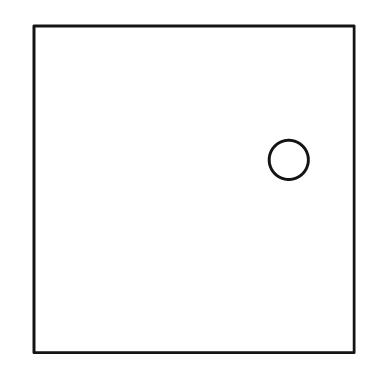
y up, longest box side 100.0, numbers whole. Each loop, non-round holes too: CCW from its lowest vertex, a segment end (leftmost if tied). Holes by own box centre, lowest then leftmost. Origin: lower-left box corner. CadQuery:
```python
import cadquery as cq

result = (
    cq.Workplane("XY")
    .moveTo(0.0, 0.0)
    .lineTo(98.0, 0.0)
    .lineTo(98.0, 100.0)
    .lineTo(0.0, 100.0)
    .close()
    .moveTo(78.0, 59.0)
    .circle(6.0)
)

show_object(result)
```